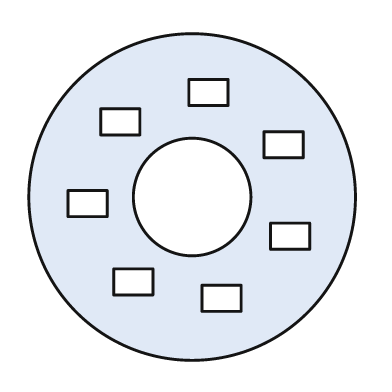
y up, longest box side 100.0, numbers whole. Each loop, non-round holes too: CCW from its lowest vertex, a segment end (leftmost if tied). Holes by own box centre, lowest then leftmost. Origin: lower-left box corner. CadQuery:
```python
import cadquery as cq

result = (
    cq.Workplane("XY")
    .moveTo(50.0, 50.0)
    .circle(50.0)
    .moveTo(53.0, 15.0)
    .lineTo(65.0, 15.0)
    .lineTo(65.0, 23.0)
    .lineTo(53.0, 23.0)
    .close()
    .moveTo(26.0, 20.0)
    .lineTo(38.0, 20.0)
    .lineTo(38.0, 28.0)
    .lineTo(26.0, 28.0)
    .close()
    .moveTo(74.0, 34.0)
    .lineTo(86.0, 34.0)
    .lineTo(86.0, 42.0)
    .lineTo(74.0, 42.0)
    .close()
    .moveTo(12.0, 44.0)
    .lineTo(24.0, 44.0)
    .lineTo(24.0, 52.0)
    .lineTo(12.0, 52.0)
    .close()
    .moveTo(50.0, 50.0)
    .circle(18.0)
    .moveTo(72.0, 62.0)
    .lineTo(84.0, 62.0)
    .lineTo(84.0, 70.0)
    .lineTo(72.0, 70.0)
    .close()
    .moveTo(22.0, 69.0)
    .lineTo(34.0, 69.0)
    .lineTo(34.0, 77.0)
    .lineTo(22.0, 77.0)
    .close()
    .moveTo(49.0, 78.0)
    .lineTo(61.0, 78.0)
    .lineTo(61.0, 86.0)
    .lineTo(49.0, 86.0)
    .close()
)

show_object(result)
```